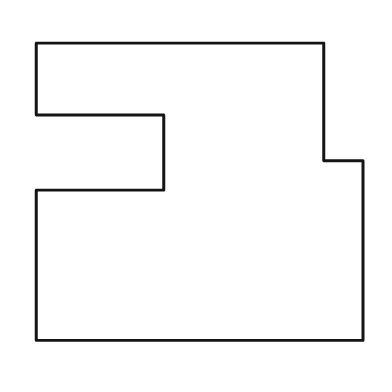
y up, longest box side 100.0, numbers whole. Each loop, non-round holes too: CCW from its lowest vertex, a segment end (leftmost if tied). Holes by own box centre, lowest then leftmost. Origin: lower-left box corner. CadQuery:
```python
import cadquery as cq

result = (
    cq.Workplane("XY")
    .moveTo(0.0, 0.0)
    .lineTo(100.0, 0.0)
    .lineTo(100.0, 55.0)
    .lineTo(88.0, 55.0)
    .lineTo(88.0, 91.0)
    .lineTo(0.0, 91.0)
    .lineTo(0.0, 69.0)
    .lineTo(39.0, 69.0)
    .lineTo(39.0, 46.0)
    .lineTo(0.0, 46.0)
    .close()
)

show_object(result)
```